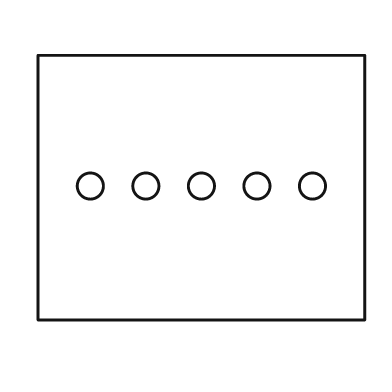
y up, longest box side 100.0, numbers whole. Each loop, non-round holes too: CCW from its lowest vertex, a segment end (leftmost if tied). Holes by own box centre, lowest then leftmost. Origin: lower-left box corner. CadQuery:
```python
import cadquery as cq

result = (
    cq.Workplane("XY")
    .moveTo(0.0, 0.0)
    .lineTo(100.0, 0.0)
    .lineTo(100.0, 81.0)
    .lineTo(0.0, 81.0)
    .close()
    .moveTo(16.0, 41.0)
    .circle(4.0)
    .moveTo(33.0, 41.0)
    .circle(4.0)
    .moveTo(50.0, 41.0)
    .circle(4.0)
    .moveTo(67.0, 41.0)
    .circle(4.0)
    .moveTo(84.0, 41.0)
    .circle(4.0)
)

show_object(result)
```